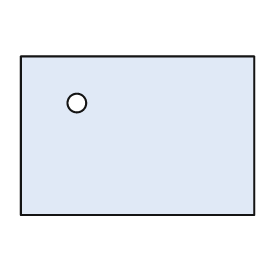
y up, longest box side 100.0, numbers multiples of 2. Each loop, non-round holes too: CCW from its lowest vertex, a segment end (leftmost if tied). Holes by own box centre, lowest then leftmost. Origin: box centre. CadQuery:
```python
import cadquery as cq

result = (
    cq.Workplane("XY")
    .moveTo(-50.0, -34.0)
    .lineTo(50.0, -34.0)
    .lineTo(50.0, 34.0)
    .lineTo(-50.0, 34.0)
    .close()
    .moveTo(-26.0, 14.0)
    .circle(4.0)
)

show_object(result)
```